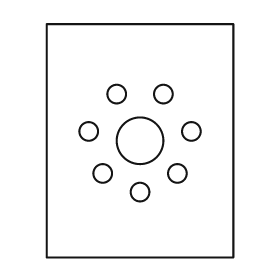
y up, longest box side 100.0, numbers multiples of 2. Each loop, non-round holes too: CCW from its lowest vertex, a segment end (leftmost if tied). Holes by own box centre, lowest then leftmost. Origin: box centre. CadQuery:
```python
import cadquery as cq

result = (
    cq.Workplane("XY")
    .moveTo(-40.0, -50.0)
    .lineTo(40.0, -50.0)
    .lineTo(40.0, 50.0)
    .lineTo(-40.0, 50.0)
    .close()
    .moveTo(0.0, -22.0)
    .circle(4.0)
    .moveTo(-16.0, -14.0)
    .circle(4.0)
    .moveTo(16.0, -14.0)
    .circle(4.0)
    .moveTo(0.0, 0.0)
    .circle(10.0)
    .moveTo(-22.0, 4.0)
    .circle(4.0)
    .moveTo(22.0, 4.0)
    .circle(4.0)
    .moveTo(-10.0, 20.0)
    .circle(4.0)
    .moveTo(10.0, 20.0)
    .circle(4.0)
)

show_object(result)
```